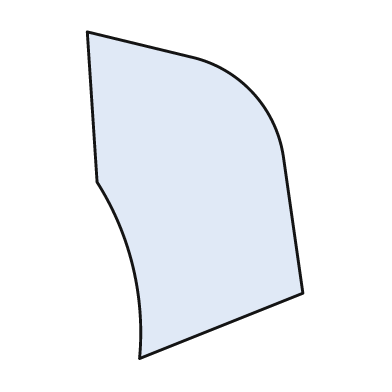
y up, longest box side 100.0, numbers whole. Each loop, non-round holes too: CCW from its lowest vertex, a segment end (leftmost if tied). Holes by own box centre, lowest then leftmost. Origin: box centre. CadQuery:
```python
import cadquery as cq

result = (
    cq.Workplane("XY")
    .moveTo(-17.0, -50.0)
    .lineTo(33.0, -30.0)
    .lineTo(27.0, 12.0)
    .threePointArc((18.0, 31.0), (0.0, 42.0))
    .lineTo(-33.0, 50.0)
    .lineTo(-30.0, 4.0)
    .threePointArc((-19.0, -22.0), (-17.0, -50.0))
    .close()
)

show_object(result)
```